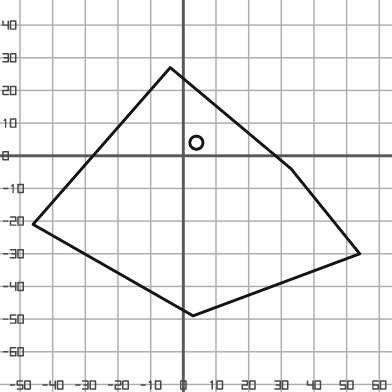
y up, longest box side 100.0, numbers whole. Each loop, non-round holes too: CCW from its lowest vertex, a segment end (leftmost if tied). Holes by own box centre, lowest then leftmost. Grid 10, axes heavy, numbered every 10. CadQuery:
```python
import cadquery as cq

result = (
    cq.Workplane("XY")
    .moveTo(3.0, -49.0)
    .lineTo(54.0, -30.0)
    .lineTo(33.0, -4.0)
    .lineTo(-4.0, 27.0)
    .lineTo(-46.0, -21.0)
    .close()
    .moveTo(4.0, 4.0)
    .circle(2.0)
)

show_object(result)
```